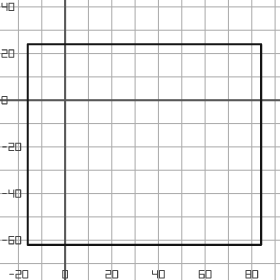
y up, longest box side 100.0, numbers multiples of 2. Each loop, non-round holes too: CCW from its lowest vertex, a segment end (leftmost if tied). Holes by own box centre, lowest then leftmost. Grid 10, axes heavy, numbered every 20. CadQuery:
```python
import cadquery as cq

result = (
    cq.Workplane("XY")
    .moveTo(-16.0, -62.0)
    .lineTo(84.0, -62.0)
    .lineTo(84.0, 24.0)
    .lineTo(-16.0, 24.0)
    .close()
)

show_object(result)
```